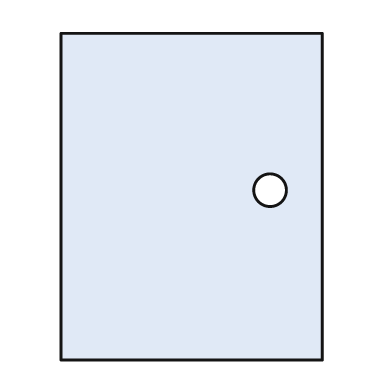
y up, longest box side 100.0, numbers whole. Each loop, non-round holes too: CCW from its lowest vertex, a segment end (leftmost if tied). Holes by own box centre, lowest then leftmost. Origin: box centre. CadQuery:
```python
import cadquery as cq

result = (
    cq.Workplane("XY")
    .moveTo(-40.0, -50.0)
    .lineTo(40.0, -50.0)
    .lineTo(40.0, 50.0)
    .lineTo(-40.0, 50.0)
    .close()
    .moveTo(24.0, 2.0)
    .circle(5.0)
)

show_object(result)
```